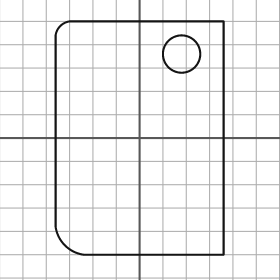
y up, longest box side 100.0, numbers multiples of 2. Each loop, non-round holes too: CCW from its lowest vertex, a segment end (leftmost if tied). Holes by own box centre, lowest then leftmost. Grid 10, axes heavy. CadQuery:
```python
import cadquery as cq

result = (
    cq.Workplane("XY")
    .moveTo(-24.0, -50.0)
    .lineTo(36.0, -50.0)
    .lineTo(36.0, 50.0)
    .lineTo(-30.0, 50.0)
    .threePointArc((-34.0, 48.0), (-36.0, 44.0))
    .lineTo(-36.0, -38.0)
    .threePointArc((-32.0, -46.0), (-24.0, -50.0))
    .close()
    .moveTo(18.0, 36.0)
    .circle(8.0)
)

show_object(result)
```